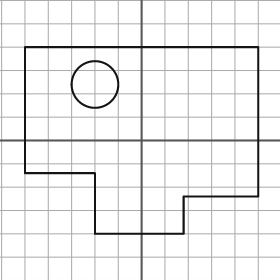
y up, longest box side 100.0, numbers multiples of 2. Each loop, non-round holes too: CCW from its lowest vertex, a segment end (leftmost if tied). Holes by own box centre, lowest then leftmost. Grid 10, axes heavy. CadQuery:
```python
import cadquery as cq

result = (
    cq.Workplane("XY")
    .moveTo(-20.0, -40.0)
    .lineTo(18.0, -40.0)
    .lineTo(18.0, -24.0)
    .lineTo(50.0, -24.0)
    .lineTo(50.0, 40.0)
    .lineTo(-50.0, 40.0)
    .lineTo(-50.0, -14.0)
    .lineTo(-20.0, -14.0)
    .close()
    .moveTo(-20.0, 24.0)
    .circle(10.0)
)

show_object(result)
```